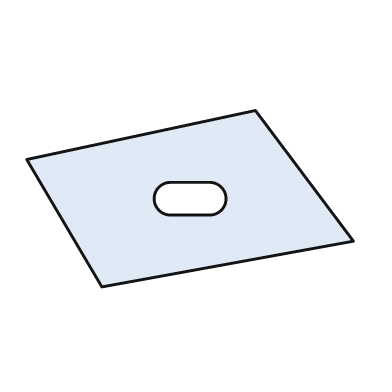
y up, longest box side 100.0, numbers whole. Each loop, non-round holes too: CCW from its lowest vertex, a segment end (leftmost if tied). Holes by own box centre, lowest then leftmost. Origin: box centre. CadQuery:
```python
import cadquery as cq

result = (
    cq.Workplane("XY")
    .moveTo(-27.0, -27.0)
    .lineTo(50.0, -13.0)
    .lineTo(20.0, 27.0)
    .lineTo(-50.0, 12.0)
    .close()
    .moveTo(-6.0, -5.0)
    .lineTo(6.0, -5.0)
    .threePointArc((11.0, 0.0), (6.0, 5.0))
    .lineTo(-6.0, 5.0)
    .threePointArc((-11.0, 0.0), (-6.0, -5.0))
    .close()
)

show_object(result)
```